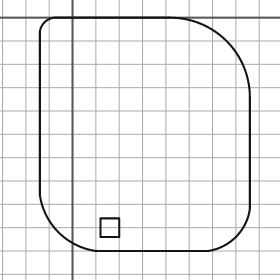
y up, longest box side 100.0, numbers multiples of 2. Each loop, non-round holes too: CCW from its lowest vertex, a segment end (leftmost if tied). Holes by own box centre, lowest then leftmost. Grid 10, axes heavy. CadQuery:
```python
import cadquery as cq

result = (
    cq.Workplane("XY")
    .moveTo(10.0, -100.0)
    .lineTo(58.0, -100.0)
    .threePointArc((70.0, -94.0), (76.0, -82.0))
    .lineTo(76.0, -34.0)
    .threePointArc((66.0, -10.0), (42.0, 0.0))
    .lineTo(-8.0, 0.0)
    .threePointArc((-12.0, -2.0), (-14.0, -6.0))
    .lineTo(-14.0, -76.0)
    .threePointArc((-6.0, -92.0), (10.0, -100.0))
    .close()
    .moveTo(12.0, -94.0)
    .lineTo(20.0, -94.0)
    .lineTo(20.0, -86.0)
    .lineTo(12.0, -86.0)
    .close()
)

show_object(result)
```